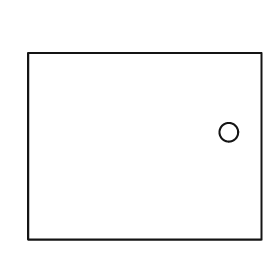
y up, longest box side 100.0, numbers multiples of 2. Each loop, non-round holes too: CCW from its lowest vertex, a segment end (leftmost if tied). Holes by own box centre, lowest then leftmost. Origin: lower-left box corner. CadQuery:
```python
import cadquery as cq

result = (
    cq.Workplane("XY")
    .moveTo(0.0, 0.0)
    .lineTo(100.0, 0.0)
    .lineTo(100.0, 80.0)
    .lineTo(0.0, 80.0)
    .close()
    .moveTo(86.0, 46.0)
    .circle(4.0)
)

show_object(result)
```